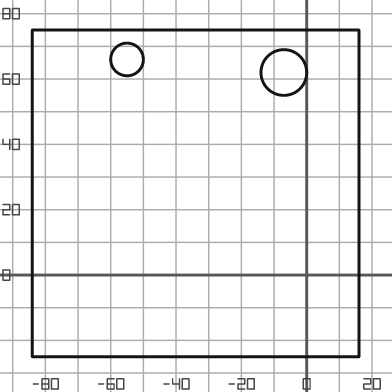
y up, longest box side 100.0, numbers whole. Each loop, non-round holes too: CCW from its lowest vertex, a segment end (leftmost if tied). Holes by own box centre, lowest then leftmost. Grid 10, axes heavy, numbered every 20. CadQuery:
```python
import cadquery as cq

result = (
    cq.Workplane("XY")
    .moveTo(-84.0, -25.0)
    .lineTo(16.0, -25.0)
    .lineTo(16.0, 75.0)
    .lineTo(-84.0, 75.0)
    .close()
    .moveTo(-7.0, 62.0)
    .circle(7.0)
    .moveTo(-55.0, 66.0)
    .circle(5.0)
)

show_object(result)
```